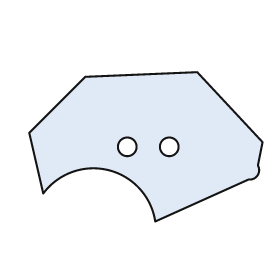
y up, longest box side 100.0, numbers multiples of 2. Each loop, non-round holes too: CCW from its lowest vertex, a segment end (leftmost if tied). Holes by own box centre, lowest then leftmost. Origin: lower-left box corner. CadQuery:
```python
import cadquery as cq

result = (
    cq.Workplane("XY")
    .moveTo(54.0, 0.0)
    .lineTo(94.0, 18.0)
    .threePointArc((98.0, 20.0), (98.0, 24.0))
    .lineTo(100.0, 34.0)
    .lineTo(72.0, 64.0)
    .lineTo(24.0, 62.0)
    .lineTo(0.0, 38.0)
    .lineTo(6.0, 12.0)
    .threePointArc((34.0, 22.0), (54.0, 0.0))
    .close()
    .moveTo(42.0, 32.0)
    .circle(4.0)
    .moveTo(60.0, 32.0)
    .circle(4.0)
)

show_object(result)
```